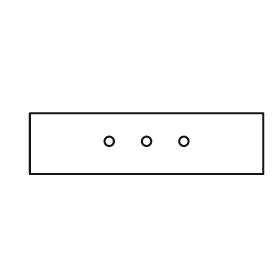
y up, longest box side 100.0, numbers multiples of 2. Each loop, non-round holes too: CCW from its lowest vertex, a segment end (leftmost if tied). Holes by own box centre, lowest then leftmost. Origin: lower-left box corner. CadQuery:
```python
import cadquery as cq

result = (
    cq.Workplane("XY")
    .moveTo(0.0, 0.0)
    .lineTo(100.0, 0.0)
    .lineTo(100.0, 26.0)
    .lineTo(0.0, 26.0)
    .close()
    .moveTo(34.0, 14.0)
    .circle(2.0)
    .moveTo(50.0, 14.0)
    .circle(2.0)
    .moveTo(66.0, 14.0)
    .circle(2.0)
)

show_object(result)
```